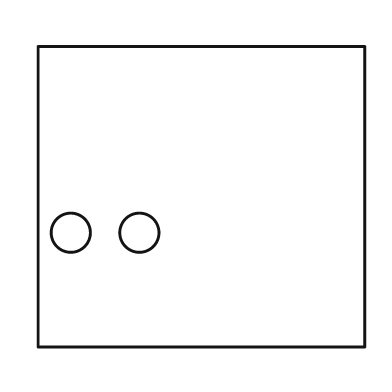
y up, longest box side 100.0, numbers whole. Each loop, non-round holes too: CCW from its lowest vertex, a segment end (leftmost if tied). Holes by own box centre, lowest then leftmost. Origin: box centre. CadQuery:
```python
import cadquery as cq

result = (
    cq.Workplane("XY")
    .moveTo(-50.0, -46.0)
    .lineTo(50.0, -46.0)
    .lineTo(50.0, 46.0)
    .lineTo(-50.0, 46.0)
    .close()
    .moveTo(-40.0, -11.0)
    .circle(6.0)
    .moveTo(-19.0, -11.0)
    .circle(6.0)
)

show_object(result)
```